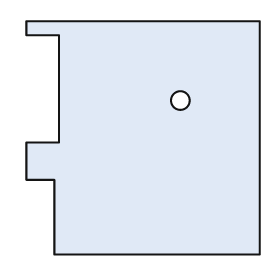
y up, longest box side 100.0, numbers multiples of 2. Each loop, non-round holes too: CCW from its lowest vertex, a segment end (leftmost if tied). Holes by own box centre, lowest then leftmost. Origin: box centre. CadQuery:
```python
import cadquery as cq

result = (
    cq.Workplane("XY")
    .moveTo(-38.0, -50.0)
    .lineTo(50.0, -50.0)
    .lineTo(50.0, 50.0)
    .lineTo(-50.0, 50.0)
    .lineTo(-50.0, 44.0)
    .lineTo(-36.0, 44.0)
    .lineTo(-36.0, -2.0)
    .lineTo(-50.0, -2.0)
    .lineTo(-50.0, -18.0)
    .lineTo(-38.0, -18.0)
    .close()
    .moveTo(16.0, 16.0)
    .circle(4.0)
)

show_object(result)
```